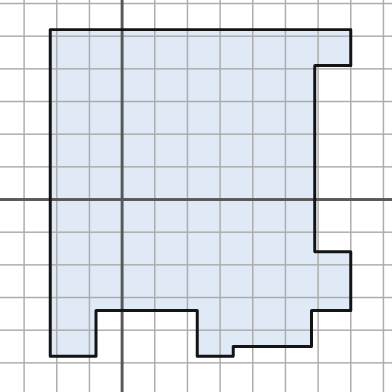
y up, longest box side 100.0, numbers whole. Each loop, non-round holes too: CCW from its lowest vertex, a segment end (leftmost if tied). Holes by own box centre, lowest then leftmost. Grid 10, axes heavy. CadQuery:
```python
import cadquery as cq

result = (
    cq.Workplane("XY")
    .moveTo(-22.0, -48.0)
    .lineTo(-8.0, -48.0)
    .lineTo(-8.0, -34.0)
    .lineTo(23.0, -34.0)
    .lineTo(23.0, -48.0)
    .lineTo(34.0, -48.0)
    .lineTo(34.0, -45.0)
    .lineTo(58.0, -45.0)
    .lineTo(58.0, -34.0)
    .lineTo(70.0, -34.0)
    .lineTo(70.0, -16.0)
    .lineTo(59.0, -16.0)
    .lineTo(59.0, 41.0)
    .lineTo(70.0, 41.0)
    .lineTo(70.0, 52.0)
    .lineTo(-22.0, 52.0)
    .close()
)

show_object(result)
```